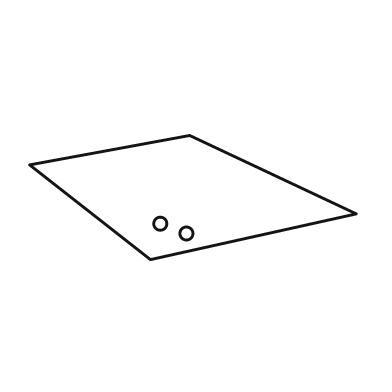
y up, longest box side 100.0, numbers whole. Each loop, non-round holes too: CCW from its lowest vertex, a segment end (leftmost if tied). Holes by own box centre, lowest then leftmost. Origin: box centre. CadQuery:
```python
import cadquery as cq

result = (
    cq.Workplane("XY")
    .moveTo(-13.0, -19.0)
    .lineTo(50.0, -5.0)
    .lineTo(-1.0, 19.0)
    .lineTo(-50.0, 10.0)
    .close()
    .moveTo(-2.0, -11.0)
    .circle(2.0)
    .moveTo(-10.0, -8.0)
    .circle(2.0)
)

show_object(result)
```